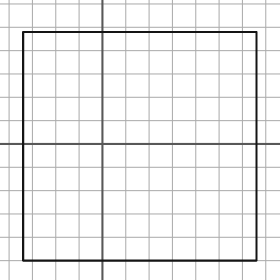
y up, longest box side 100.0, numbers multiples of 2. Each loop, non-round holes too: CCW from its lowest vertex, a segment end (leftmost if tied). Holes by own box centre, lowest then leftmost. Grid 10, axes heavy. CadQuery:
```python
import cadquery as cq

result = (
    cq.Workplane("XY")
    .moveTo(-34.0, -50.0)
    .lineTo(66.0, -50.0)
    .lineTo(66.0, 48.0)
    .lineTo(-34.0, 48.0)
    .close()
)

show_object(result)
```